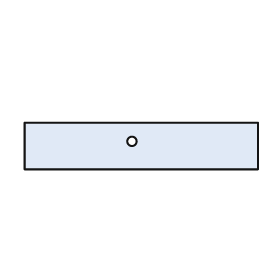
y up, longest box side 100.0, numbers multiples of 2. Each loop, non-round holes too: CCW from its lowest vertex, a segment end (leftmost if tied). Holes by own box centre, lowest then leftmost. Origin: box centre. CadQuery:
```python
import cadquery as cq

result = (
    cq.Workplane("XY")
    .moveTo(-50.0, -10.0)
    .lineTo(50.0, -10.0)
    .lineTo(50.0, 10.0)
    .lineTo(-50.0, 10.0)
    .close()
    .moveTo(-4.0, 2.0)
    .circle(2.0)
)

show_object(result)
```